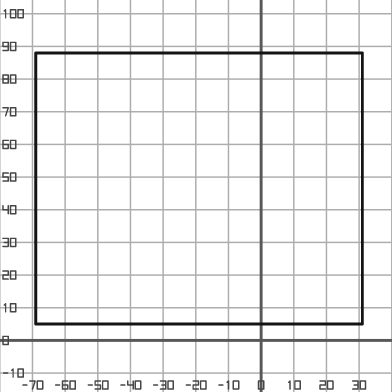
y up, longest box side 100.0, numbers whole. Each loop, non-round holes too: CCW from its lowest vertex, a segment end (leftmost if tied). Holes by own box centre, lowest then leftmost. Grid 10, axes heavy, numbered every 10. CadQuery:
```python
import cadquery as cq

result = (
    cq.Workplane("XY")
    .moveTo(-69.0, 5.0)
    .lineTo(31.0, 5.0)
    .lineTo(31.0, 88.0)
    .lineTo(-69.0, 88.0)
    .close()
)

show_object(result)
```